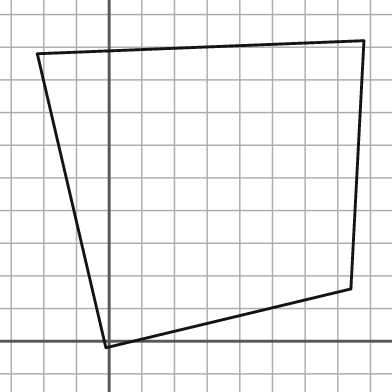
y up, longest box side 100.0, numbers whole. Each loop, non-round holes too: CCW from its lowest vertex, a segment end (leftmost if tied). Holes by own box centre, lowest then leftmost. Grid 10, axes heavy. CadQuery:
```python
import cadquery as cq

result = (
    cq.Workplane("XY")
    .moveTo(-1.0, -2.0)
    .lineTo(74.0, 16.0)
    .lineTo(78.0, 92.0)
    .lineTo(-22.0, 88.0)
    .close()
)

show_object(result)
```